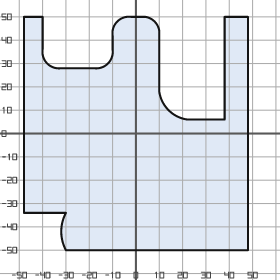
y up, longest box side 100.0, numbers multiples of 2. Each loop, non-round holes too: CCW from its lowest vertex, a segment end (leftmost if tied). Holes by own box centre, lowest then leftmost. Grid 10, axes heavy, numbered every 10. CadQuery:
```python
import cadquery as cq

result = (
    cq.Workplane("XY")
    .moveTo(-30.0, -50.0)
    .lineTo(48.0, -50.0)
    .lineTo(48.0, 50.0)
    .lineTo(38.0, 50.0)
    .lineTo(38.0, 6.0)
    .lineTo(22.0, 6.0)
    .threePointArc((14.0, 10.0), (10.0, 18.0))
    .lineTo(10.0, 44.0)
    .threePointArc((8.0, 48.0), (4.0, 50.0))
    .lineTo(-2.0, 50.0)
    .threePointArc((-8.0, 48.0), (-10.0, 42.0))
    .lineTo(-10.0, 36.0)
    .threePointArc((-12.0, 30.0), (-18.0, 28.0))
    .lineTo(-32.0, 28.0)
    .threePointArc((-38.0, 30.0), (-40.0, 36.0))
    .lineTo(-40.0, 50.0)
    .lineTo(-48.0, 50.0)
    .lineTo(-48.0, -34.0)
    .lineTo(-30.0, -34.0)
    .threePointArc((-32.0, -42.0), (-30.0, -50.0))
    .close()
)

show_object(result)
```